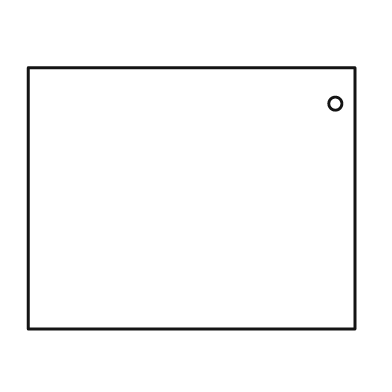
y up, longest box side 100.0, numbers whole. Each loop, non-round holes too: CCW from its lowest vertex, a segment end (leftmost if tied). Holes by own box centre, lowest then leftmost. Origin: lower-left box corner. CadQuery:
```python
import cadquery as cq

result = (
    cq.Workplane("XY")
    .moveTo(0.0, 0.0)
    .lineTo(100.0, 0.0)
    .lineTo(100.0, 80.0)
    .lineTo(0.0, 80.0)
    .close()
    .moveTo(94.0, 69.0)
    .circle(2.0)
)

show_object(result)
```